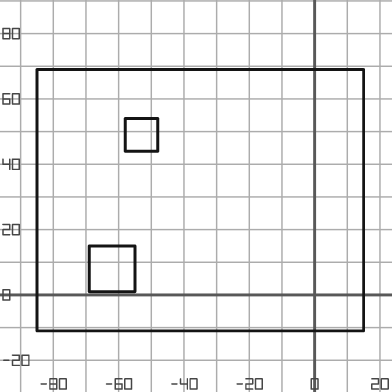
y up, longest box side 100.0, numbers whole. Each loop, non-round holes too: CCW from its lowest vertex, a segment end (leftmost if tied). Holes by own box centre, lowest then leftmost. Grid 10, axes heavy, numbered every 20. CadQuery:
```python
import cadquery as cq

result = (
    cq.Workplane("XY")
    .moveTo(-85.0, -11.0)
    .lineTo(15.0, -11.0)
    .lineTo(15.0, 69.0)
    .lineTo(-85.0, 69.0)
    .close()
    .moveTo(-69.0, 1.0)
    .lineTo(-55.0, 1.0)
    .lineTo(-55.0, 15.0)
    .lineTo(-69.0, 15.0)
    .close()
    .moveTo(-58.0, 44.0)
    .lineTo(-48.0, 44.0)
    .lineTo(-48.0, 54.0)
    .lineTo(-58.0, 54.0)
    .close()
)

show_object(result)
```